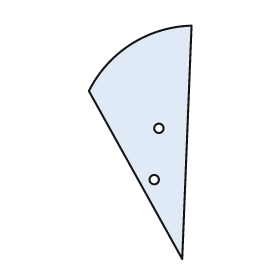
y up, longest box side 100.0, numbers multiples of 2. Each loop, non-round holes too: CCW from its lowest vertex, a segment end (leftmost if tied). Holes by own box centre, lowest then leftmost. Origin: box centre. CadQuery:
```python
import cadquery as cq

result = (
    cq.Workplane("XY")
    .moveTo(18.0, -50.0)
    .lineTo(22.0, 50.0)
    .threePointArc((-4.0, 42.0), (-22.0, 22.0))
    .close()
    .moveTo(6.0, -16.0)
    .circle(2.0)
    .moveTo(8.0, 6.0)
    .circle(2.0)
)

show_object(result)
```